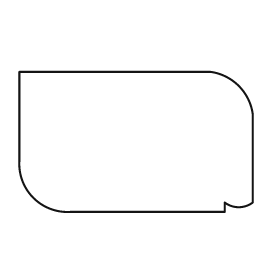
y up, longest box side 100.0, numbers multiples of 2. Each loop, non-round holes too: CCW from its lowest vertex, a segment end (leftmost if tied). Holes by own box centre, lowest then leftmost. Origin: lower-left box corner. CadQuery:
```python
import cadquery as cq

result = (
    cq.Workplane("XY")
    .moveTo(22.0, 0.0)
    .lineTo(88.0, 0.0)
    .lineTo(88.0, 4.0)
    .threePointArc((94.0, 2.0), (100.0, 4.0))
    .lineTo(100.0, 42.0)
    .threePointArc((94.0, 54.0), (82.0, 60.0))
    .lineTo(0.0, 60.0)
    .lineTo(0.0, 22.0)
    .threePointArc((6.0, 6.0), (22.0, 0.0))
    .close()
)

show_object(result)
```